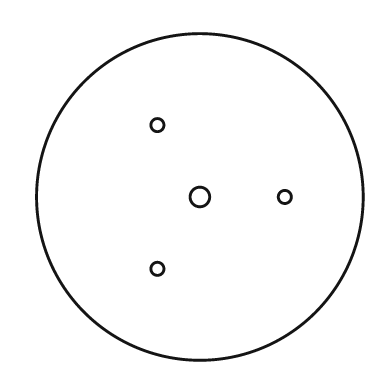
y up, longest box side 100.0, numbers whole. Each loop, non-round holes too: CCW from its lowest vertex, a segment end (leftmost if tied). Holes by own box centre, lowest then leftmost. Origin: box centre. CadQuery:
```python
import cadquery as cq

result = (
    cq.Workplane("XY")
    .moveTo(0.0, 0.0)
    .circle(50.0)
    .moveTo(-13.0, -22.0)
    .circle(2.0)
    .moveTo(0.0, 0.0)
    .circle(3.0)
    .moveTo(26.0, 0.0)
    .circle(2.0)
    .moveTo(-13.0, 22.0)
    .circle(2.0)
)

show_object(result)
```